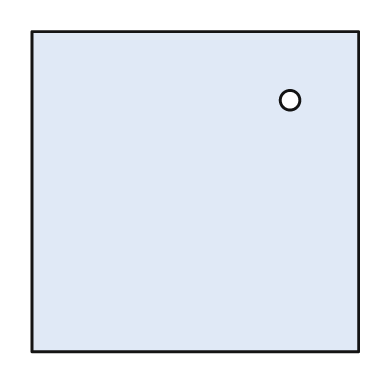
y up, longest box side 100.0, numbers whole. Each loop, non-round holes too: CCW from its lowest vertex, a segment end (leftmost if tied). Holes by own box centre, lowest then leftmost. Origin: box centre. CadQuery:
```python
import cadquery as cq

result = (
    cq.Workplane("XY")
    .moveTo(-50.0, -49.0)
    .lineTo(50.0, -49.0)
    .lineTo(50.0, 49.0)
    .lineTo(-50.0, 49.0)
    .close()
    .moveTo(29.0, 28.0)
    .circle(3.0)
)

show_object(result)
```